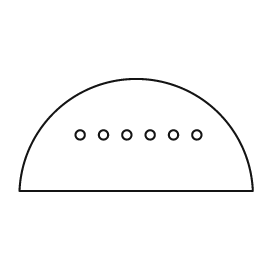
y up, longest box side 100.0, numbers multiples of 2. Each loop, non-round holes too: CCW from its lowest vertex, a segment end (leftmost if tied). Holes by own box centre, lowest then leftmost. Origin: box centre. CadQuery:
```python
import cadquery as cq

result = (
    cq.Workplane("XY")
    .moveTo(-50.0, -24.0)
    .lineTo(50.0, -24.0)
    .threePointArc((0.0, 24.0), (-50.0, -24.0))
    .close()
    .moveTo(-24.0, 0.0)
    .circle(2.0)
    .moveTo(-14.0, 0.0)
    .circle(2.0)
    .moveTo(-4.0, 0.0)
    .circle(2.0)
    .moveTo(6.0, 0.0)
    .circle(2.0)
    .moveTo(16.0, 0.0)
    .circle(2.0)
    .moveTo(26.0, 0.0)
    .circle(2.0)
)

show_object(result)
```